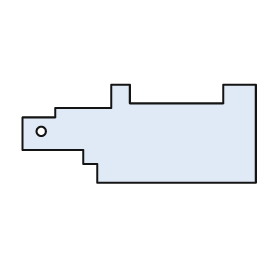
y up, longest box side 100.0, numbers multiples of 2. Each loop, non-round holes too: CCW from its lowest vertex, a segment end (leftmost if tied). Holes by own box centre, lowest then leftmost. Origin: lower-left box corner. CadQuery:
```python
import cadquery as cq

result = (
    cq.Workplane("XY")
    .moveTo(32.0, 0.0)
    .lineTo(100.0, 0.0)
    .lineTo(100.0, 42.0)
    .lineTo(86.0, 42.0)
    .lineTo(86.0, 34.0)
    .lineTo(46.0, 34.0)
    .lineTo(46.0, 42.0)
    .lineTo(38.0, 42.0)
    .lineTo(38.0, 32.0)
    .lineTo(14.0, 32.0)
    .lineTo(14.0, 28.0)
    .lineTo(0.0, 28.0)
    .lineTo(0.0, 14.0)
    .lineTo(26.0, 14.0)
    .lineTo(26.0, 8.0)
    .lineTo(32.0, 8.0)
    .close()
    .moveTo(8.0, 22.0)
    .circle(2.0)
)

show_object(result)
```